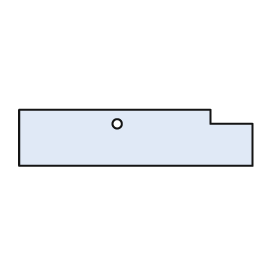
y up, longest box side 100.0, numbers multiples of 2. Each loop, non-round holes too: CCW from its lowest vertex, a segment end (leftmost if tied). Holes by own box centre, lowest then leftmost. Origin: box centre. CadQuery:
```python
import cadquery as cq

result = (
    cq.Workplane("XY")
    .moveTo(-50.0, -12.0)
    .lineTo(50.0, -12.0)
    .lineTo(50.0, 6.0)
    .lineTo(32.0, 6.0)
    .lineTo(32.0, 12.0)
    .lineTo(-50.0, 12.0)
    .close()
    .moveTo(-8.0, 6.0)
    .circle(2.0)
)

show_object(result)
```